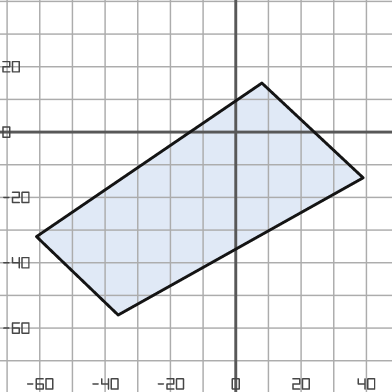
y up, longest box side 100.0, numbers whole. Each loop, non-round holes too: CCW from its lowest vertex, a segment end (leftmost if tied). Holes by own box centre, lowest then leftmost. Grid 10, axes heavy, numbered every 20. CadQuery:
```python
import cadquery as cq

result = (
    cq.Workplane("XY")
    .moveTo(-36.0, -56.0)
    .lineTo(39.0, -14.0)
    .lineTo(8.0, 15.0)
    .lineTo(-61.0, -32.0)
    .close()
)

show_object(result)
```